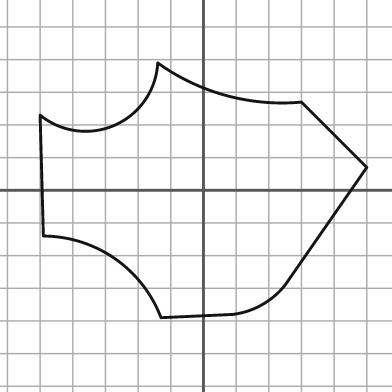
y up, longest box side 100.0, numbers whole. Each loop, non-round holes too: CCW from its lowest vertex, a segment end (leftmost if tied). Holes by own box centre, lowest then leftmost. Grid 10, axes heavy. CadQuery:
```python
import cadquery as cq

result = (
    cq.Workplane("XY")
    .moveTo(-13.0, -39.0)
    .lineTo(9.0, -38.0)
    .threePointArc((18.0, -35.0), (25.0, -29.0))
    .lineTo(50.0, 7.0)
    .lineTo(30.0, 27.0)
    .threePointArc((7.0, 29.0), (-14.0, 39.0))
    .threePointArc((-27.0, 20.0), (-50.0, 23.0))
    .lineTo(-49.0, -14.0)
    .threePointArc((-27.0, -21.0), (-13.0, -39.0))
    .close()
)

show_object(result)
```